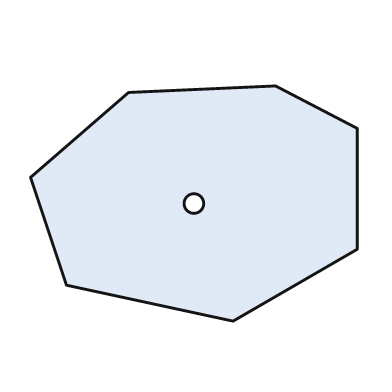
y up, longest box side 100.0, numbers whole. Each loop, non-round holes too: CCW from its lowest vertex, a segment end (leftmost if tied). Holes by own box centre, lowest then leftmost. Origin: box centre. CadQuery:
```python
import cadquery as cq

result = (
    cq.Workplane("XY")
    .moveTo(12.0, -36.0)
    .lineTo(50.0, -14.0)
    .lineTo(50.0, 23.0)
    .lineTo(25.0, 36.0)
    .lineTo(-20.0, 34.0)
    .lineTo(-50.0, 8.0)
    .lineTo(-39.0, -25.0)
    .close()
    .moveTo(0.0, 0.0)
    .circle(3.0)
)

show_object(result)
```